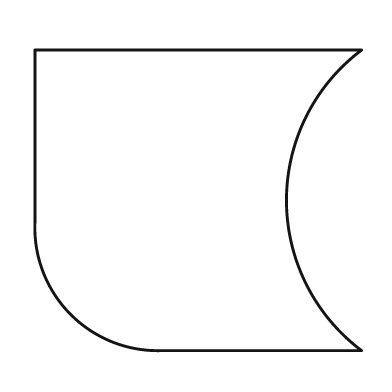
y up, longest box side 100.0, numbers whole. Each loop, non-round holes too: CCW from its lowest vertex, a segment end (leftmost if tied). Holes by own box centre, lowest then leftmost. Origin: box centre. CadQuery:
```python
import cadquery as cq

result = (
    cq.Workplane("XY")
    .moveTo(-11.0, -46.0)
    .lineTo(50.0, -46.0)
    .threePointArc((27.0, 0.0), (50.0, 46.0))
    .lineTo(-50.0, 46.0)
    .lineTo(-50.0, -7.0)
    .threePointArc((-39.0, -35.0), (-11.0, -46.0))
    .close()
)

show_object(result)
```